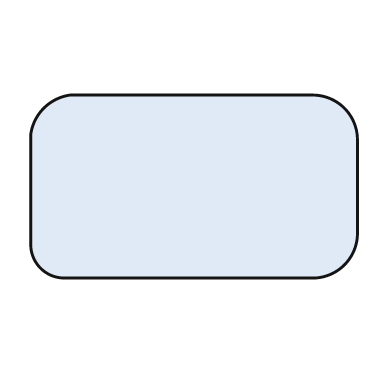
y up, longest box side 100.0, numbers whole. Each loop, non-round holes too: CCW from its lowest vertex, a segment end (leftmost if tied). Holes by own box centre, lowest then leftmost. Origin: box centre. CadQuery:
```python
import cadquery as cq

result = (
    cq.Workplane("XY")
    .moveTo(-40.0, -28.0)
    .lineTo(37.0, -28.0)
    .threePointArc((46.0, -24.0), (50.0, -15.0))
    .lineTo(50.0, 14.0)
    .threePointArc((46.0, 24.0), (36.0, 28.0))
    .lineTo(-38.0, 28.0)
    .threePointArc((-46.0, 24.0), (-50.0, 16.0))
    .lineTo(-50.0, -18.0)
    .threePointArc((-47.0, -25.0), (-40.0, -28.0))
    .close()
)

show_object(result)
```